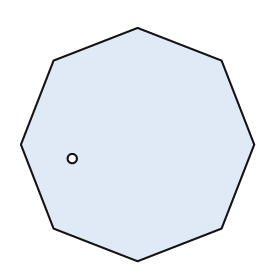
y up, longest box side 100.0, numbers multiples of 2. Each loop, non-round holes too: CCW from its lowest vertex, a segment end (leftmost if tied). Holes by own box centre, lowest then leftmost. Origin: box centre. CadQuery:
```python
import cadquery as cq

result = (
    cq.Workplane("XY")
    .moveTo(0.0, -50.0)
    .lineTo(36.0, -36.0)
    .lineTo(50.0, 0.0)
    .lineTo(36.0, 36.0)
    .lineTo(0.0, 50.0)
    .lineTo(-36.0, 36.0)
    .lineTo(-50.0, 0.0)
    .lineTo(-36.0, -36.0)
    .close()
    .moveTo(-28.0, -6.0)
    .circle(2.0)
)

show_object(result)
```